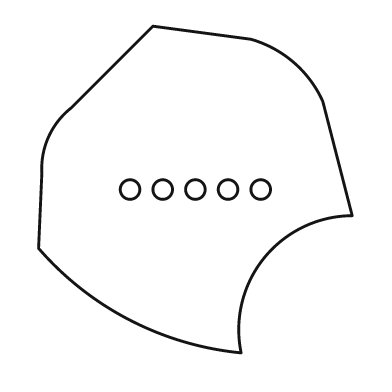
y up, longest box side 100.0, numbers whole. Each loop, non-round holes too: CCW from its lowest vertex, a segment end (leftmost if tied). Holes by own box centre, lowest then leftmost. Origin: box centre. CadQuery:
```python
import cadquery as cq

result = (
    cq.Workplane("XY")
    .moveTo(14.0, -50.0)
    .threePointArc((21.0, -21.0), (48.0, -8.0))
    .lineTo(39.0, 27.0)
    .threePointArc((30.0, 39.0), (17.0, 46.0))
    .lineTo(-13.0, 50.0)
    .lineTo(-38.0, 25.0)
    .threePointArc((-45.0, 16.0), (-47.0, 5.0))
    .lineTo(-48.0, -18.0)
    .threePointArc((-20.0, -40.0), (14.0, -50.0))
    .close()
    .moveTo(-20.0, 0.0)
    .circle(3.0)
    .moveTo(-10.0, 0.0)
    .circle(3.0)
    .moveTo(0.0, 0.0)
    .circle(3.0)
    .moveTo(10.0, 0.0)
    .circle(3.0)
    .moveTo(20.0, 0.0)
    .circle(3.0)
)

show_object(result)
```